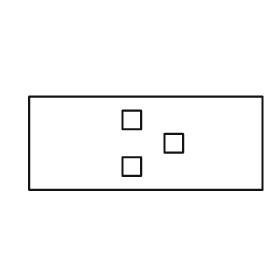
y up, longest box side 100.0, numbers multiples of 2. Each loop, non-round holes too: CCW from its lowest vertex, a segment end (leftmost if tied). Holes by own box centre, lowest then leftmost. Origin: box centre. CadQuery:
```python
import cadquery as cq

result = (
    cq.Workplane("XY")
    .moveTo(-50.0, -20.0)
    .lineTo(50.0, -20.0)
    .lineTo(50.0, 20.0)
    .lineTo(-50.0, 20.0)
    .close()
    .moveTo(-10.0, -14.0)
    .lineTo(-2.0, -14.0)
    .lineTo(-2.0, -6.0)
    .lineTo(-10.0, -6.0)
    .close()
    .moveTo(8.0, -4.0)
    .lineTo(16.0, -4.0)
    .lineTo(16.0, 4.0)
    .lineTo(8.0, 4.0)
    .close()
    .moveTo(-10.0, 6.0)
    .lineTo(-2.0, 6.0)
    .lineTo(-2.0, 14.0)
    .lineTo(-10.0, 14.0)
    .close()
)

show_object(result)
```